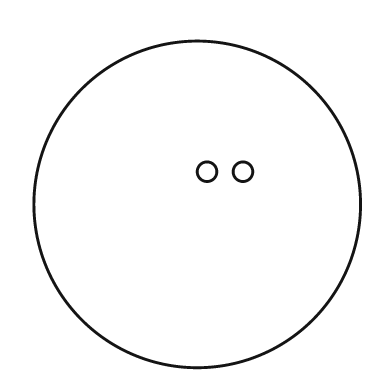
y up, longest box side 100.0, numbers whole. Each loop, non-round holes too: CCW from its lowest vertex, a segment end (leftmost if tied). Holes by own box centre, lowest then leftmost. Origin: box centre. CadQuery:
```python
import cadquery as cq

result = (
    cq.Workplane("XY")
    .moveTo(0.0, 0.0)
    .circle(50.0)
    .moveTo(3.0, 10.0)
    .circle(3.0)
    .moveTo(14.0, 10.0)
    .circle(3.0)
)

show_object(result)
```